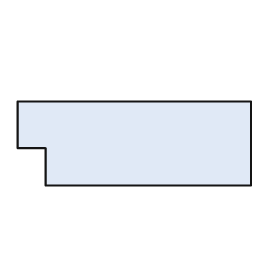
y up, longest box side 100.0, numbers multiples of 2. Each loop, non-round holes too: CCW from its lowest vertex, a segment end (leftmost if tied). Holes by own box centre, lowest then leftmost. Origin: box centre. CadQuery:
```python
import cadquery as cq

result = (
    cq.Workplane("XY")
    .moveTo(-38.0, -18.0)
    .lineTo(50.0, -18.0)
    .lineTo(50.0, 18.0)
    .lineTo(-50.0, 18.0)
    .lineTo(-50.0, -2.0)
    .lineTo(-38.0, -2.0)
    .close()
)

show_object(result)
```